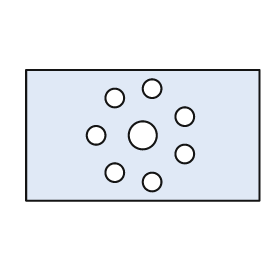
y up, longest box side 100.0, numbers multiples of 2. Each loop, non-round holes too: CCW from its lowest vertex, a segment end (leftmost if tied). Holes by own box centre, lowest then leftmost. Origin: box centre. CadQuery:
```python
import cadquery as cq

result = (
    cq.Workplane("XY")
    .moveTo(-50.0, -28.0)
    .lineTo(50.0, -28.0)
    .lineTo(50.0, 28.0)
    .lineTo(-50.0, 28.0)
    .close()
    .moveTo(4.0, -20.0)
    .circle(4.0)
    .moveTo(-12.0, -16.0)
    .circle(4.0)
    .moveTo(18.0, -8.0)
    .circle(4.0)
    .moveTo(-20.0, 0.0)
    .circle(4.0)
    .moveTo(0.0, 0.0)
    .circle(6.0)
    .moveTo(18.0, 8.0)
    .circle(4.0)
    .moveTo(-12.0, 16.0)
    .circle(4.0)
    .moveTo(4.0, 20.0)
    .circle(4.0)
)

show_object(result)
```